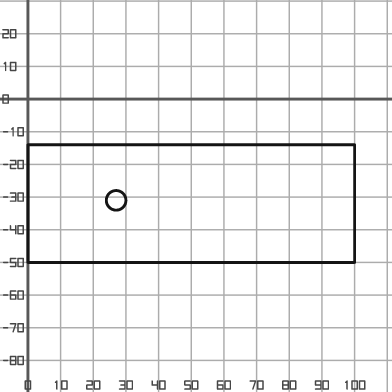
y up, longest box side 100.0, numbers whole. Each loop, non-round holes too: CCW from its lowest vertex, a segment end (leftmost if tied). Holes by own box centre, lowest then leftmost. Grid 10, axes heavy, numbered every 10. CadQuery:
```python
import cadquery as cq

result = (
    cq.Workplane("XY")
    .moveTo(0.0, -50.0)
    .lineTo(100.0, -50.0)
    .lineTo(100.0, -14.0)
    .lineTo(0.0, -14.0)
    .close()
    .moveTo(27.0, -31.0)
    .circle(3.0)
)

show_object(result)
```